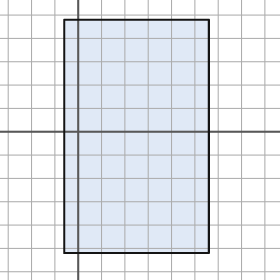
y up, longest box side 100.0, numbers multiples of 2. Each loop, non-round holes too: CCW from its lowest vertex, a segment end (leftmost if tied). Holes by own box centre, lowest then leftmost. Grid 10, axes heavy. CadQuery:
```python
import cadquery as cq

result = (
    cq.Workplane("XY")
    .moveTo(-6.0, -52.0)
    .lineTo(56.0, -52.0)
    .lineTo(56.0, 48.0)
    .lineTo(-6.0, 48.0)
    .close()
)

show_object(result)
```